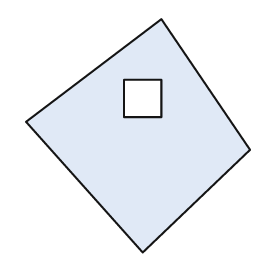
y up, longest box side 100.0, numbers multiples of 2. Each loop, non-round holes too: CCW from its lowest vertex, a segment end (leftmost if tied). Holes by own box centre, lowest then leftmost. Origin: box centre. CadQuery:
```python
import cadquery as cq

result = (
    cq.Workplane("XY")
    .moveTo(2.0, -50.0)
    .lineTo(48.0, -6.0)
    .lineTo(10.0, 50.0)
    .lineTo(-48.0, 6.0)
    .close()
    .moveTo(-6.0, 8.0)
    .lineTo(10.0, 8.0)
    .lineTo(10.0, 24.0)
    .lineTo(-6.0, 24.0)
    .close()
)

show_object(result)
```